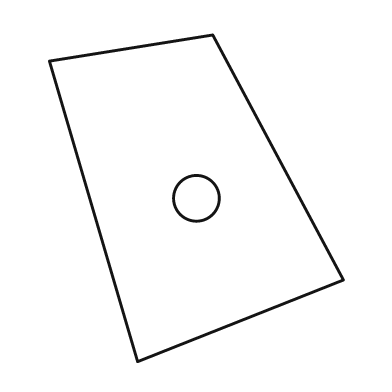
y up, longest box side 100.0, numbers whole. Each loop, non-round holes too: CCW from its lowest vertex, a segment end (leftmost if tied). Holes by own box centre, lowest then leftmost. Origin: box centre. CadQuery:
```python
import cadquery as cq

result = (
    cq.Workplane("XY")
    .moveTo(-18.0, -50.0)
    .lineTo(45.0, -25.0)
    .lineTo(5.0, 50.0)
    .lineTo(-45.0, 42.0)
    .close()
    .moveTo(0.0, 0.0)
    .circle(7.0)
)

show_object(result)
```